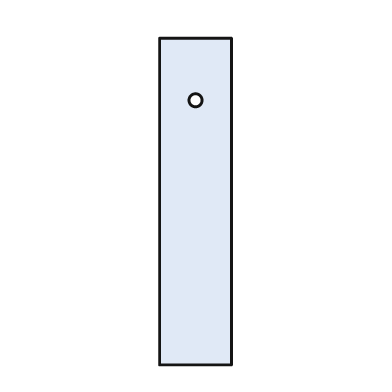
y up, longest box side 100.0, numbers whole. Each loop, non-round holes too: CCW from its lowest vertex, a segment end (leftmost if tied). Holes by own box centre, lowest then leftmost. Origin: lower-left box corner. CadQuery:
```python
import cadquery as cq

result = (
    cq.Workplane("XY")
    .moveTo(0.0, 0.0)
    .lineTo(22.0, 0.0)
    .lineTo(22.0, 100.0)
    .lineTo(0.0, 100.0)
    .close()
    .moveTo(11.0, 81.0)
    .circle(2.0)
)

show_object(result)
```